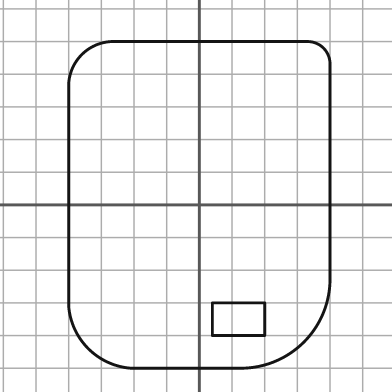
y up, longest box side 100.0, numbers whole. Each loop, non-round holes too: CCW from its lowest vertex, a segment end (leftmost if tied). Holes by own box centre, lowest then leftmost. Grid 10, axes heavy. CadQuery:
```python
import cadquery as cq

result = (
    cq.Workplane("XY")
    .moveTo(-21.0, -50.0)
    .lineTo(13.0, -50.0)
    .threePointArc((32.0, -42.0), (40.0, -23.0))
    .lineTo(40.0, 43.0)
    .threePointArc((38.0, 48.0), (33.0, 50.0))
    .lineTo(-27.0, 50.0)
    .threePointArc((-36.0, 46.0), (-40.0, 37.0))
    .lineTo(-40.0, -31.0)
    .threePointArc((-34.0, -44.0), (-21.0, -50.0))
    .close()
    .moveTo(4.0, -40.0)
    .lineTo(20.0, -40.0)
    .lineTo(20.0, -30.0)
    .lineTo(4.0, -30.0)
    .close()
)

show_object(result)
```